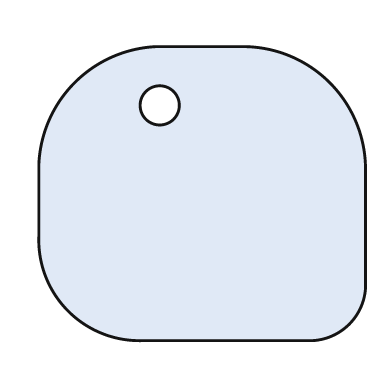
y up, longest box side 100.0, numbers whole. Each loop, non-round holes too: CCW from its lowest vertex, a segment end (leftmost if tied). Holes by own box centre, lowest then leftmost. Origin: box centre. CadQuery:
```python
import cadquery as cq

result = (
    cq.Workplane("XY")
    .moveTo(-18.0, -45.0)
    .lineTo(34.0, -45.0)
    .threePointArc((45.0, -40.0), (50.0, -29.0))
    .lineTo(50.0, 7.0)
    .threePointArc((39.0, 34.0), (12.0, 45.0))
    .lineTo(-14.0, 45.0)
    .threePointArc((-39.0, 34.0), (-50.0, 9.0))
    .lineTo(-50.0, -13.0)
    .threePointArc((-41.0, -36.0), (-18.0, -45.0))
    .close()
    .moveTo(-13.0, 27.0)
    .circle(6.0)
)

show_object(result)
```